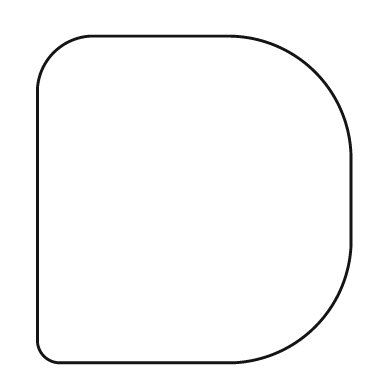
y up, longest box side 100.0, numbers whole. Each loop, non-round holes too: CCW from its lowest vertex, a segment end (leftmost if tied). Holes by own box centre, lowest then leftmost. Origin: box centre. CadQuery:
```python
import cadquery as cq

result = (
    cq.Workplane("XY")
    .moveTo(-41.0, -50.0)
    .lineTo(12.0, -50.0)
    .threePointArc((37.0, -39.0), (48.0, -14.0))
    .lineTo(48.0, 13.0)
    .threePointArc((37.0, 39.0), (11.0, 50.0))
    .lineTo(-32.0, 50.0)
    .threePointArc((-43.0, 45.0), (-48.0, 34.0))
    .lineTo(-48.0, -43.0)
    .threePointArc((-46.0, -48.0), (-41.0, -50.0))
    .close()
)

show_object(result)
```